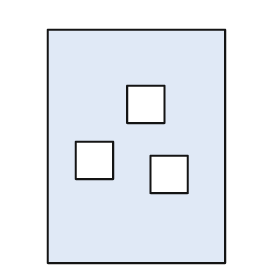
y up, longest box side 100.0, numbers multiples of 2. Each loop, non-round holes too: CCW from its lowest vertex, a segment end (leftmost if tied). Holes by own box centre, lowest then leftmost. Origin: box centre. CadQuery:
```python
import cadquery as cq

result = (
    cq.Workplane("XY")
    .moveTo(-38.0, -50.0)
    .lineTo(38.0, -50.0)
    .lineTo(38.0, 50.0)
    .lineTo(-38.0, 50.0)
    .close()
    .moveTo(6.0, -20.0)
    .lineTo(22.0, -20.0)
    .lineTo(22.0, -4.0)
    .lineTo(6.0, -4.0)
    .close()
    .moveTo(-26.0, -14.0)
    .lineTo(-10.0, -14.0)
    .lineTo(-10.0, 2.0)
    .lineTo(-26.0, 2.0)
    .close()
    .moveTo(-4.0, 10.0)
    .lineTo(12.0, 10.0)
    .lineTo(12.0, 26.0)
    .lineTo(-4.0, 26.0)
    .close()
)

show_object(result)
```